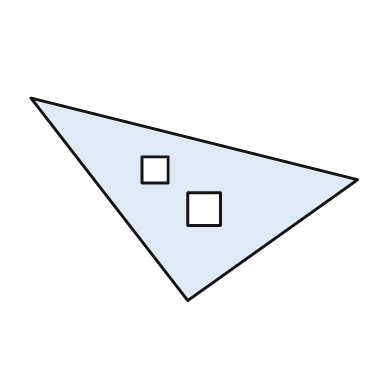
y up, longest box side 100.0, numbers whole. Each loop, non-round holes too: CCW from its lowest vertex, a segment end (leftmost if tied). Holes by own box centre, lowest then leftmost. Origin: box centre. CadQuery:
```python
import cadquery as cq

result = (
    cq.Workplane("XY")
    .moveTo(-2.0, -31.0)
    .lineTo(50.0, 6.0)
    .lineTo(-50.0, 31.0)
    .close()
    .moveTo(-2.0, -8.0)
    .lineTo(8.0, -8.0)
    .lineTo(8.0, 2.0)
    .lineTo(-2.0, 2.0)
    .close()
    .moveTo(-16.0, 5.0)
    .lineTo(-8.0, 5.0)
    .lineTo(-8.0, 13.0)
    .lineTo(-16.0, 13.0)
    .close()
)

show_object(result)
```